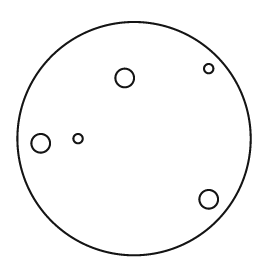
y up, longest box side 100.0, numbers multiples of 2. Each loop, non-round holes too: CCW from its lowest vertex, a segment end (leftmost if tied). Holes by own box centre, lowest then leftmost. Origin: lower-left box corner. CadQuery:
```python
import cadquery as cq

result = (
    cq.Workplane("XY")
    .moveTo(50.0, 50.0)
    .circle(50.0)
    .moveTo(82.0, 24.0)
    .circle(4.0)
    .moveTo(10.0, 48.0)
    .circle(4.0)
    .moveTo(26.0, 50.0)
    .circle(2.0)
    .moveTo(46.0, 76.0)
    .circle(4.0)
    .moveTo(82.0, 80.0)
    .circle(2.0)
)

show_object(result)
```